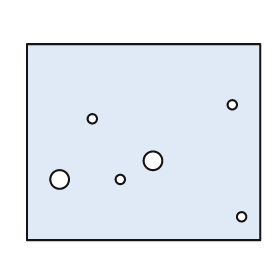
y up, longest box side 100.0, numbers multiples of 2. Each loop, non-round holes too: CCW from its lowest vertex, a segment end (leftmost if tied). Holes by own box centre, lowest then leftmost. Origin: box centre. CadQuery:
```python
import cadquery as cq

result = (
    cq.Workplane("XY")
    .moveTo(-50.0, -42.0)
    .lineTo(50.0, -42.0)
    .lineTo(50.0, 42.0)
    .lineTo(-50.0, 42.0)
    .close()
    .moveTo(42.0, -32.0)
    .circle(2.0)
    .moveTo(-36.0, -16.0)
    .circle(4.0)
    .moveTo(-10.0, -16.0)
    .circle(2.0)
    .moveTo(4.0, -8.0)
    .circle(4.0)
    .moveTo(-22.0, 10.0)
    .circle(2.0)
    .moveTo(38.0, 16.0)
    .circle(2.0)
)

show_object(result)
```